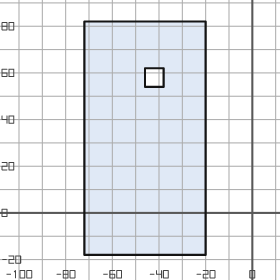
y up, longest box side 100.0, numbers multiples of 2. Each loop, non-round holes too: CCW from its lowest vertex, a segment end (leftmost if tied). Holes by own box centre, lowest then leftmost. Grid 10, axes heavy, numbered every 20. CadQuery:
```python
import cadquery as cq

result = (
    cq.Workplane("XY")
    .moveTo(-72.0, -18.0)
    .lineTo(-20.0, -18.0)
    .lineTo(-20.0, 82.0)
    .lineTo(-72.0, 82.0)
    .close()
    .moveTo(-46.0, 54.0)
    .lineTo(-38.0, 54.0)
    .lineTo(-38.0, 62.0)
    .lineTo(-46.0, 62.0)
    .close()
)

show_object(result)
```